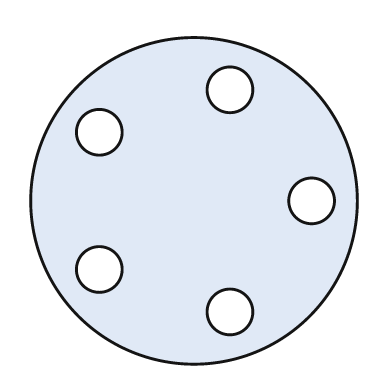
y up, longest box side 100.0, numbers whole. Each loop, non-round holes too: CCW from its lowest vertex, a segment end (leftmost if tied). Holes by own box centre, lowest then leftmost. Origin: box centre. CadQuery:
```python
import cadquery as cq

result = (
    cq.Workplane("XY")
    .moveTo(0.0, 0.0)
    .circle(50.0)
    .moveTo(11.0, -34.0)
    .circle(7.0)
    .moveTo(-29.0, -21.0)
    .circle(7.0)
    .moveTo(36.0, 0.0)
    .circle(7.0)
    .moveTo(-29.0, 21.0)
    .circle(7.0)
    .moveTo(11.0, 34.0)
    .circle(7.0)
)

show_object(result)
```